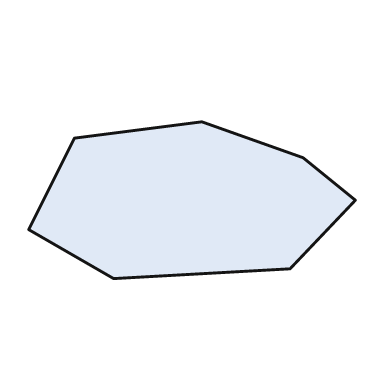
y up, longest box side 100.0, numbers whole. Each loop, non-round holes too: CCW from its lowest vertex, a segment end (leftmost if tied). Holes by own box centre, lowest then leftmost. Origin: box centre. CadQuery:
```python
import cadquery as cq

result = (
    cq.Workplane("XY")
    .moveTo(-24.0, -24.0)
    .lineTo(30.0, -21.0)
    .lineTo(50.0, 0.0)
    .lineTo(34.0, 13.0)
    .lineTo(3.0, 24.0)
    .lineTo(-36.0, 19.0)
    .lineTo(-50.0, -9.0)
    .close()
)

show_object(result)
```